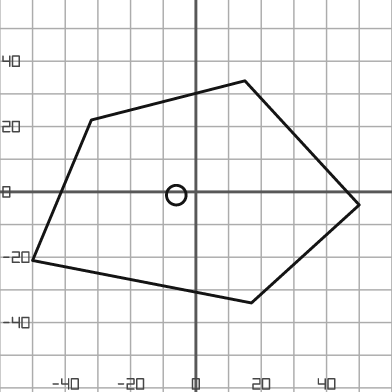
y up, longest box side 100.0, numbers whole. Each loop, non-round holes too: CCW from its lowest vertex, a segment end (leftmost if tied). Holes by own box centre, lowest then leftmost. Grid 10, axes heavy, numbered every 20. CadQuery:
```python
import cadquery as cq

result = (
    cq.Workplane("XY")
    .moveTo(17.0, -34.0)
    .lineTo(50.0, -4.0)
    .lineTo(15.0, 34.0)
    .lineTo(-32.0, 22.0)
    .lineTo(-50.0, -21.0)
    .close()
    .moveTo(-6.0, -1.0)
    .circle(3.0)
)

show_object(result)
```